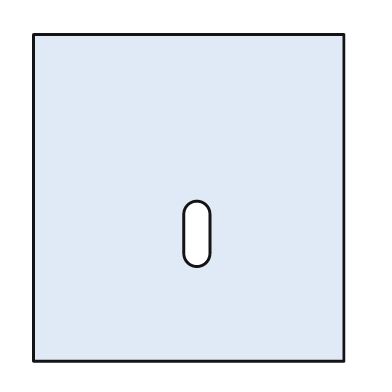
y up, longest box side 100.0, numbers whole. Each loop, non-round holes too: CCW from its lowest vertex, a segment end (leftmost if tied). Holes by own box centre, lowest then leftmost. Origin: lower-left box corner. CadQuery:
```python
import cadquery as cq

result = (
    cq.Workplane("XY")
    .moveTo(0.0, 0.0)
    .lineTo(95.0, 0.0)
    .lineTo(95.0, 100.0)
    .lineTo(0.0, 100.0)
    .close()
    .moveTo(46.0, 33.0)
    .threePointArc((50.0, 29.0), (54.0, 33.0))
    .lineTo(54.0, 45.0)
    .threePointArc((50.0, 49.0), (46.0, 45.0))
    .close()
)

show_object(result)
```